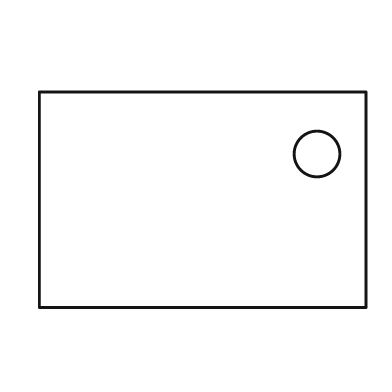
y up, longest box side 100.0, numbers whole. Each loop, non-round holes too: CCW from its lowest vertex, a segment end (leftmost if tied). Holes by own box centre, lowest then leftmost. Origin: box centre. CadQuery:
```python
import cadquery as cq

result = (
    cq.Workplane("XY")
    .moveTo(-50.0, -33.0)
    .lineTo(50.0, -33.0)
    .lineTo(50.0, 33.0)
    .lineTo(-50.0, 33.0)
    .close()
    .moveTo(35.0, 14.0)
    .circle(7.0)
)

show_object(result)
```